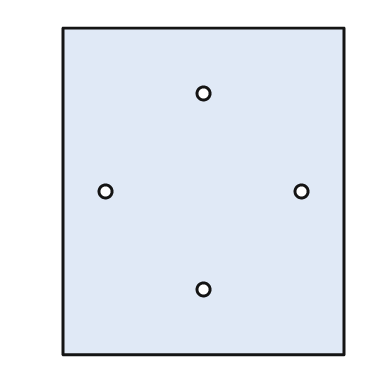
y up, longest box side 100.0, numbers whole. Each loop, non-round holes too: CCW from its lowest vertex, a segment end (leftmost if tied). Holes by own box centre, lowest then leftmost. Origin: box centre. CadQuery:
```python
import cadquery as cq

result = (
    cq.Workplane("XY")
    .moveTo(-43.0, -50.0)
    .lineTo(43.0, -50.0)
    .lineTo(43.0, 50.0)
    .lineTo(-43.0, 50.0)
    .close()
    .moveTo(0.0, -30.0)
    .circle(2.0)
    .moveTo(-30.0, 0.0)
    .circle(2.0)
    .moveTo(30.0, 0.0)
    .circle(2.0)
    .moveTo(0.0, 30.0)
    .circle(2.0)
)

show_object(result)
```